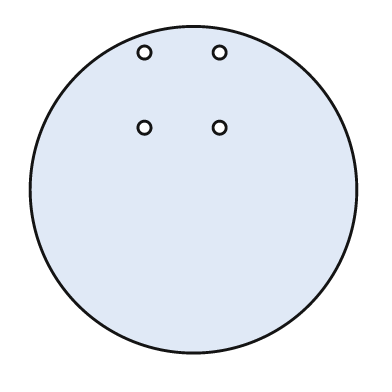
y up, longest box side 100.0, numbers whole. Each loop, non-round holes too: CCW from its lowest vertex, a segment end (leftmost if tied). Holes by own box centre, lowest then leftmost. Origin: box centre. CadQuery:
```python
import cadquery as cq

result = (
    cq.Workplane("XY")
    .moveTo(0.0, 0.0)
    .circle(50.0)
    .moveTo(-15.0, 19.0)
    .circle(2.0)
    .moveTo(8.0, 19.0)
    .circle(2.0)
    .moveTo(-15.0, 42.0)
    .circle(2.0)
    .moveTo(8.0, 42.0)
    .circle(2.0)
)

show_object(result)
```